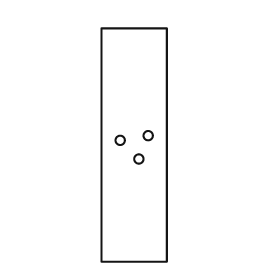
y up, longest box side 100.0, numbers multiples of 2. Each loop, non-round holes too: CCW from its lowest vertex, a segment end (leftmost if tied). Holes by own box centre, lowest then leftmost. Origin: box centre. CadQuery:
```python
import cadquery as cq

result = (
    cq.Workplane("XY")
    .moveTo(-14.0, -50.0)
    .lineTo(14.0, -50.0)
    .lineTo(14.0, 50.0)
    .lineTo(-14.0, 50.0)
    .close()
    .moveTo(2.0, -6.0)
    .circle(2.0)
    .moveTo(-6.0, 2.0)
    .circle(2.0)
    .moveTo(6.0, 4.0)
    .circle(2.0)
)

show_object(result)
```